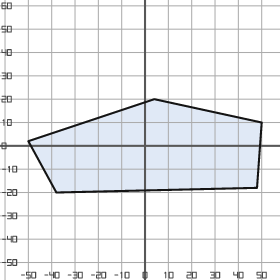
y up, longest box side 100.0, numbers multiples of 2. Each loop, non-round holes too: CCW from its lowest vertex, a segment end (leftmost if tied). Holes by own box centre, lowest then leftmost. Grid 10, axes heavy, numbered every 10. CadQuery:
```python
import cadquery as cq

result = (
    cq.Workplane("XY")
    .moveTo(-38.0, -20.0)
    .lineTo(48.0, -18.0)
    .lineTo(50.0, 10.0)
    .lineTo(4.0, 20.0)
    .lineTo(-50.0, 2.0)
    .close()
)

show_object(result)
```